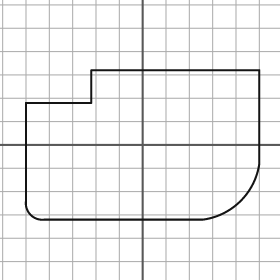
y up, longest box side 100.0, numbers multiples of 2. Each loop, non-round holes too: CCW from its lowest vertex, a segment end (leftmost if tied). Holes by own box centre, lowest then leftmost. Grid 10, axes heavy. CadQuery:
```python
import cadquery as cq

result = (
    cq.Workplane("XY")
    .moveTo(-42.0, -32.0)
    .lineTo(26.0, -32.0)
    .threePointArc((42.0, -24.0), (50.0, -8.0))
    .lineTo(50.0, 32.0)
    .lineTo(-22.0, 32.0)
    .lineTo(-22.0, 18.0)
    .lineTo(-50.0, 18.0)
    .lineTo(-50.0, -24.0)
    .threePointArc((-48.0, -30.0), (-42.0, -32.0))
    .close()
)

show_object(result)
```